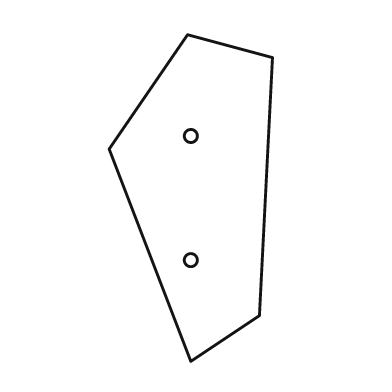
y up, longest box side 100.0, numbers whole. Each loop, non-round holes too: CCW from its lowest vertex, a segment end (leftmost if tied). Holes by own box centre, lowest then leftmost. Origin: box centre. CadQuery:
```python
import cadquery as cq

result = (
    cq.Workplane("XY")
    .moveTo(0.0, -50.0)
    .lineTo(21.0, -36.0)
    .lineTo(25.0, 43.0)
    .lineTo(-1.0, 50.0)
    .lineTo(-25.0, 15.0)
    .close()
    .moveTo(0.0, -19.0)
    .circle(2.0)
    .moveTo(0.0, 19.0)
    .circle(2.0)
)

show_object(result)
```